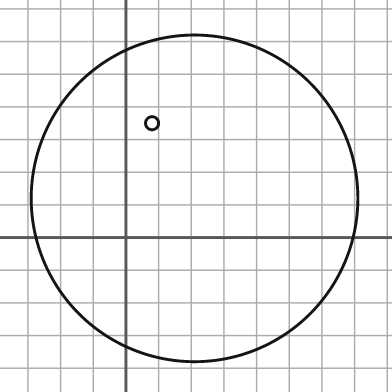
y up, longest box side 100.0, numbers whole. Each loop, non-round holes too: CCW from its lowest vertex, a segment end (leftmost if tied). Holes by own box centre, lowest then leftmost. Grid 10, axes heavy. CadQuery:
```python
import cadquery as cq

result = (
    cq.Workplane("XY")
    .moveTo(21.0, 12.0)
    .circle(50.0)
    .moveTo(8.0, 35.0)
    .circle(2.0)
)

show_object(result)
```